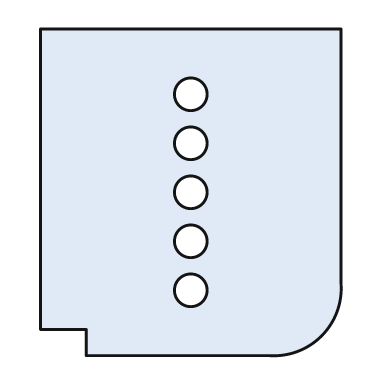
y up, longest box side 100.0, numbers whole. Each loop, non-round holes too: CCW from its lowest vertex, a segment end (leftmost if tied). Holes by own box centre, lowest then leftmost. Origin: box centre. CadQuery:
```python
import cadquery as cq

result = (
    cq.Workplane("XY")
    .moveTo(-32.0, -50.0)
    .lineTo(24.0, -50.0)
    .threePointArc((40.0, -44.0), (46.0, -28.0))
    .lineTo(46.0, 50.0)
    .lineTo(-46.0, 50.0)
    .lineTo(-46.0, -42.0)
    .lineTo(-32.0, -42.0)
    .close()
    .moveTo(0.0, -30.0)
    .circle(5.0)
    .moveTo(0.0, -15.0)
    .circle(5.0)
    .moveTo(0.0, 0.0)
    .circle(5.0)
    .moveTo(0.0, 15.0)
    .circle(5.0)
    .moveTo(0.0, 30.0)
    .circle(5.0)
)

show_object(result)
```